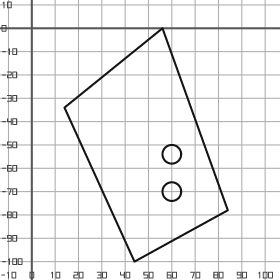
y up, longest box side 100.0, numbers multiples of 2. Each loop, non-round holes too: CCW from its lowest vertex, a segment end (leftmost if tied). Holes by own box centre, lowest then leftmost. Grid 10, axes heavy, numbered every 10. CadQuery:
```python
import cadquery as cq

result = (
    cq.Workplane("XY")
    .moveTo(44.0, -100.0)
    .lineTo(84.0, -78.0)
    .lineTo(56.0, 0.0)
    .lineTo(14.0, -34.0)
    .close()
    .moveTo(60.0, -70.0)
    .circle(4.0)
    .moveTo(60.0, -54.0)
    .circle(4.0)
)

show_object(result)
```